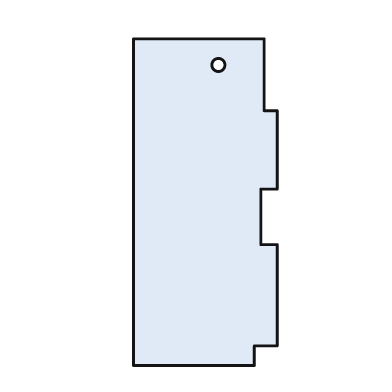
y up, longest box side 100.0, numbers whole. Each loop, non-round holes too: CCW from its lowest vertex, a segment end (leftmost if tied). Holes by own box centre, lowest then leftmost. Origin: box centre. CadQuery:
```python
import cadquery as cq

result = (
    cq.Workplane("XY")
    .moveTo(-22.0, -50.0)
    .lineTo(15.0, -50.0)
    .lineTo(15.0, -44.0)
    .lineTo(22.0, -44.0)
    .lineTo(22.0, -13.0)
    .lineTo(17.0, -13.0)
    .lineTo(17.0, 4.0)
    .lineTo(22.0, 4.0)
    .lineTo(22.0, 28.0)
    .lineTo(18.0, 28.0)
    .lineTo(18.0, 50.0)
    .lineTo(-22.0, 50.0)
    .close()
    .moveTo(4.0, 42.0)
    .circle(2.0)
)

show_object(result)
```